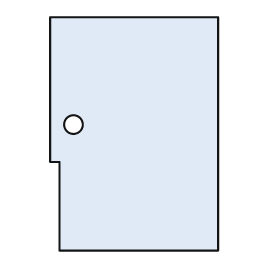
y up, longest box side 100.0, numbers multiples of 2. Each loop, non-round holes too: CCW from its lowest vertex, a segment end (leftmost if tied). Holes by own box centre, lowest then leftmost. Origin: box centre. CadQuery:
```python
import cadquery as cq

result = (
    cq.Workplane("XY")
    .moveTo(-32.0, -50.0)
    .lineTo(36.0, -50.0)
    .lineTo(36.0, 50.0)
    .lineTo(-36.0, 50.0)
    .lineTo(-36.0, -12.0)
    .lineTo(-32.0, -12.0)
    .close()
    .moveTo(-26.0, 4.0)
    .circle(4.0)
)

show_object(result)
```